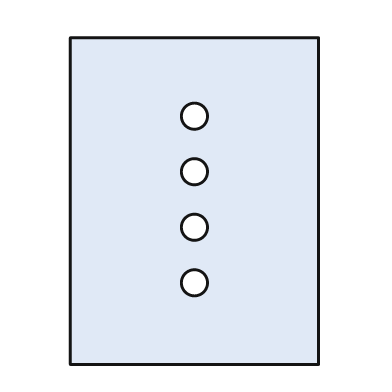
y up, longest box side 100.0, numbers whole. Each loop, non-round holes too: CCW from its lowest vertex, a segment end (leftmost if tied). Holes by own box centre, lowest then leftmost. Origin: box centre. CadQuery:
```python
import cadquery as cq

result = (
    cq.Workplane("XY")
    .moveTo(-38.0, -50.0)
    .lineTo(38.0, -50.0)
    .lineTo(38.0, 50.0)
    .lineTo(-38.0, 50.0)
    .close()
    .moveTo(0.0, -25.0)
    .circle(4.0)
    .moveTo(0.0, -8.0)
    .circle(4.0)
    .moveTo(0.0, 9.0)
    .circle(4.0)
    .moveTo(0.0, 26.0)
    .circle(4.0)
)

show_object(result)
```